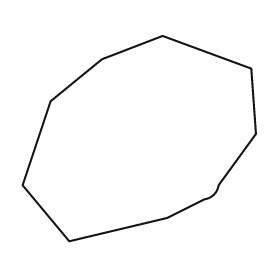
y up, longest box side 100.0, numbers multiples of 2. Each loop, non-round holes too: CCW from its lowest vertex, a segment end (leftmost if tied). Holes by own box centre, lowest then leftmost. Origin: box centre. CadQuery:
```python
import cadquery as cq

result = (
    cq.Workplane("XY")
    .moveTo(-30.0, -44.0)
    .lineTo(12.0, -34.0)
    .lineTo(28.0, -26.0)
    .threePointArc((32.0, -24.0), (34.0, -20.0))
    .lineTo(50.0, 2.0)
    .lineTo(48.0, 30.0)
    .lineTo(10.0, 44.0)
    .lineTo(-16.0, 34.0)
    .lineTo(-38.0, 16.0)
    .lineTo(-50.0, -20.0)
    .close()
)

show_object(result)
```